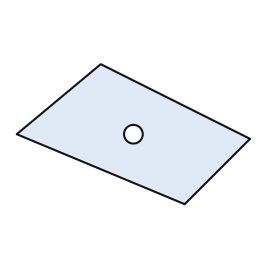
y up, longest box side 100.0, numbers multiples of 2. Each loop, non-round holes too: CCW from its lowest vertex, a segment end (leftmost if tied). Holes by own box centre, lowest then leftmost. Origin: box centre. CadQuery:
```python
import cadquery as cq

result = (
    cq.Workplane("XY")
    .moveTo(22.0, -30.0)
    .lineTo(50.0, -2.0)
    .lineTo(-14.0, 30.0)
    .lineTo(-50.0, 0.0)
    .close()
    .moveTo(0.0, 0.0)
    .circle(4.0)
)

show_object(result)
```